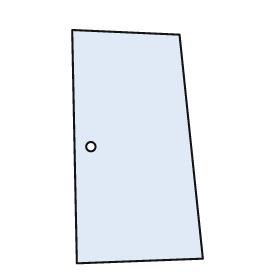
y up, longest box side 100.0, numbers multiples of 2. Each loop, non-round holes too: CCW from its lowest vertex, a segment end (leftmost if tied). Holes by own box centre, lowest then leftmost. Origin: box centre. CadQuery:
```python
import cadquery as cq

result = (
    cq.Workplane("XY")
    .moveTo(-26.0, -50.0)
    .lineTo(28.0, -48.0)
    .lineTo(18.0, 48.0)
    .lineTo(-28.0, 50.0)
    .close()
    .moveTo(-20.0, 0.0)
    .circle(2.0)
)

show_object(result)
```